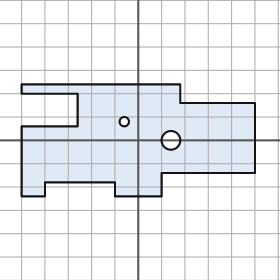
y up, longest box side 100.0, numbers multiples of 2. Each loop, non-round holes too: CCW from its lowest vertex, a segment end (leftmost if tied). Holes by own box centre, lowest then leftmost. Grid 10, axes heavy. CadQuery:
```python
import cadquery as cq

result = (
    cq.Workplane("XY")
    .moveTo(-50.0, -24.0)
    .lineTo(-40.0, -24.0)
    .lineTo(-40.0, -18.0)
    .lineTo(-10.0, -18.0)
    .lineTo(-10.0, -24.0)
    .lineTo(10.0, -24.0)
    .lineTo(10.0, -14.0)
    .lineTo(50.0, -14.0)
    .lineTo(50.0, 16.0)
    .lineTo(18.0, 16.0)
    .lineTo(18.0, 24.0)
    .lineTo(-50.0, 24.0)
    .lineTo(-50.0, 20.0)
    .lineTo(-26.0, 20.0)
    .lineTo(-26.0, 6.0)
    .lineTo(-50.0, 6.0)
    .close()
    .moveTo(14.0, 0.0)
    .circle(4.0)
    .moveTo(-6.0, 8.0)
    .circle(2.0)
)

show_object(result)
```